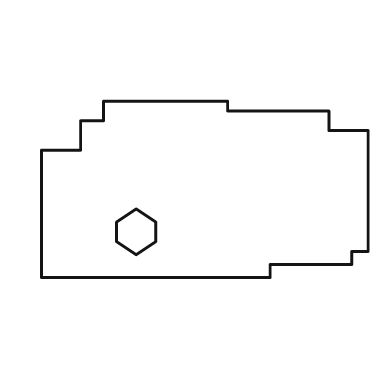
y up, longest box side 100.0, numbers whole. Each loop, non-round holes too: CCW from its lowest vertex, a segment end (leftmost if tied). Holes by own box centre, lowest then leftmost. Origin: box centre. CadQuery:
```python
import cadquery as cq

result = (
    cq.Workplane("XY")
    .moveTo(-50.0, -27.0)
    .lineTo(20.0, -27.0)
    .lineTo(20.0, -23.0)
    .lineTo(45.0, -23.0)
    .lineTo(45.0, -19.0)
    .lineTo(50.0, -19.0)
    .lineTo(50.0, 18.0)
    .lineTo(38.0, 18.0)
    .lineTo(38.0, 24.0)
    .lineTo(7.0, 24.0)
    .lineTo(7.0, 27.0)
    .lineTo(-31.0, 27.0)
    .lineTo(-31.0, 21.0)
    .lineTo(-38.0, 21.0)
    .lineTo(-38.0, 12.0)
    .lineTo(-50.0, 12.0)
    .close()
    .moveTo(-21.0, -20.0)
    .lineTo(-15.0, -16.0)
    .lineTo(-15.0, -10.0)
    .lineTo(-21.0, -6.0)
    .lineTo(-27.0, -10.0)
    .lineTo(-27.0, -16.0)
    .close()
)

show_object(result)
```